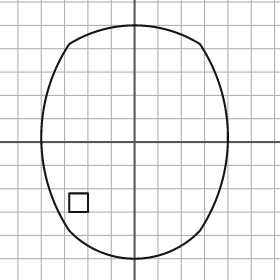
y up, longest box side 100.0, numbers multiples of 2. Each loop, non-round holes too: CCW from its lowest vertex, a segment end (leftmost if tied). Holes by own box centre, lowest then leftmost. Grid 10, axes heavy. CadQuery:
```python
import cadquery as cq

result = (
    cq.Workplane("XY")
    .moveTo(-28.0, -38.0)
    .threePointArc((0.0, -50.0), (28.0, -38.0))
    .threePointArc((40.0, 2.0), (28.0, 42.0))
    .threePointArc((0.0, 50.0), (-28.0, 42.0))
    .threePointArc((-40.0, 2.0), (-28.0, -38.0))
    .close()
    .moveTo(-28.0, -30.0)
    .lineTo(-20.0, -30.0)
    .lineTo(-20.0, -22.0)
    .lineTo(-28.0, -22.0)
    .close()
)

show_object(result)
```